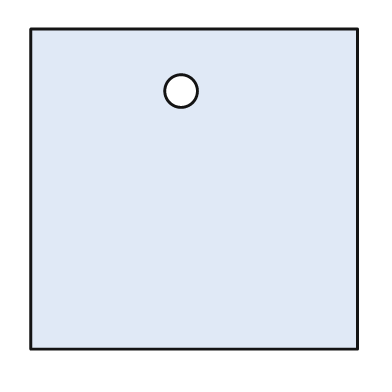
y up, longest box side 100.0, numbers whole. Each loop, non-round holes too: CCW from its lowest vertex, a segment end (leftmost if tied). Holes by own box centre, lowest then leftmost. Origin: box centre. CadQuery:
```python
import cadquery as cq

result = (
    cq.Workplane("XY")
    .moveTo(-50.0, -49.0)
    .lineTo(50.0, -49.0)
    .lineTo(50.0, 49.0)
    .lineTo(-50.0, 49.0)
    .close()
    .moveTo(-4.0, 30.0)
    .circle(5.0)
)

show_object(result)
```